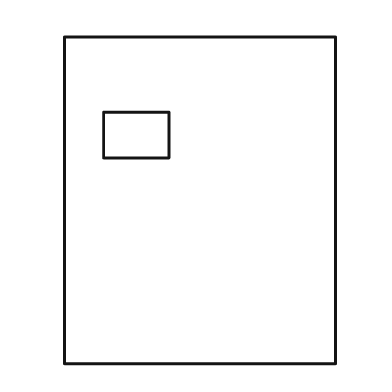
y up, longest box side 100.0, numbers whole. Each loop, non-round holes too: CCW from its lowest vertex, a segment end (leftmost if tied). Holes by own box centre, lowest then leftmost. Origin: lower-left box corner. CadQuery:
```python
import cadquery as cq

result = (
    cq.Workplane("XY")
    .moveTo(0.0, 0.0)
    .lineTo(83.0, 0.0)
    .lineTo(83.0, 100.0)
    .lineTo(0.0, 100.0)
    .close()
    .moveTo(12.0, 63.0)
    .lineTo(32.0, 63.0)
    .lineTo(32.0, 77.0)
    .lineTo(12.0, 77.0)
    .close()
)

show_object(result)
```